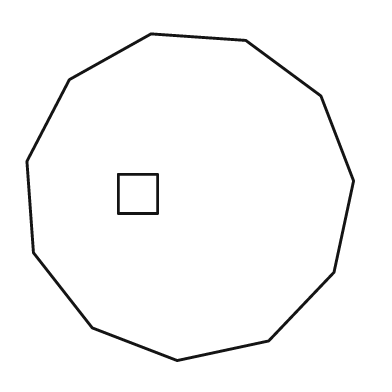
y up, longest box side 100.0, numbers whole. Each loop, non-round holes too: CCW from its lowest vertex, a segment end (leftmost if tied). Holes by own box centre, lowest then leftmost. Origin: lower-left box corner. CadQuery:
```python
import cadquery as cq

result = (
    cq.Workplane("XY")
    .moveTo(46.0, 0.0)
    .lineTo(74.0, 6.0)
    .lineTo(94.0, 27.0)
    .lineTo(100.0, 55.0)
    .lineTo(90.0, 81.0)
    .lineTo(67.0, 98.0)
    .lineTo(38.0, 100.0)
    .lineTo(13.0, 86.0)
    .lineTo(0.0, 61.0)
    .lineTo(2.0, 33.0)
    .lineTo(20.0, 10.0)
    .close()
    .moveTo(28.0, 45.0)
    .lineTo(40.0, 45.0)
    .lineTo(40.0, 57.0)
    .lineTo(28.0, 57.0)
    .close()
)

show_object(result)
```